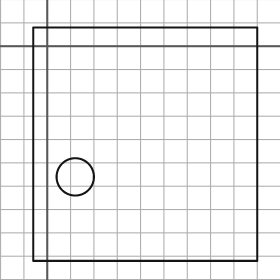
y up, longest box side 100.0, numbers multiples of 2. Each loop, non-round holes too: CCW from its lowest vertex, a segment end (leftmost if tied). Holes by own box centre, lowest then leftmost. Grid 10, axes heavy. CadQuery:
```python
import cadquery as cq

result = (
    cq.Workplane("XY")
    .moveTo(-6.0, -92.0)
    .lineTo(90.0, -92.0)
    .lineTo(90.0, 8.0)
    .lineTo(-6.0, 8.0)
    .close()
    .moveTo(12.0, -56.0)
    .circle(8.0)
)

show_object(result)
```